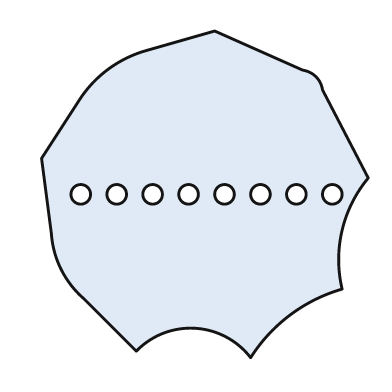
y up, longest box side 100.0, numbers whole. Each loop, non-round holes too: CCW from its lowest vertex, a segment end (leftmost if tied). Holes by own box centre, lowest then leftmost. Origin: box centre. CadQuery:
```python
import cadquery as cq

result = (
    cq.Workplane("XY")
    .moveTo(14.0, -50.0)
    .threePointArc((26.0, -37.0), (42.0, -29.0))
    .threePointArc((42.0, -11.0), (50.0, 5.0))
    .lineTo(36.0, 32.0)
    .threePointArc((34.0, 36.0), (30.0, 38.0))
    .lineTo(3.0, 50.0)
    .lineTo(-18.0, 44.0)
    .threePointArc((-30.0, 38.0), (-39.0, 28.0))
    .lineTo(-50.0, 11.0)
    .lineTo(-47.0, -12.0)
    .threePointArc((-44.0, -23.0), (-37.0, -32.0))
    .lineTo(-21.0, -48.0)
    .threePointArc((-3.0, -41.0), (14.0, -50.0))
    .close()
    .moveTo(-38.0, 0.0)
    .circle(3.0)
    .moveTo(-27.0, 0.0)
    .circle(3.0)
    .moveTo(-16.0, 0.0)
    .circle(3.0)
    .moveTo(-5.0, 0.0)
    .circle(3.0)
    .moveTo(6.0, 0.0)
    .circle(3.0)
    .moveTo(17.0, 0.0)
    .circle(3.0)
    .moveTo(28.0, 0.0)
    .circle(3.0)
    .moveTo(39.0, 0.0)
    .circle(3.0)
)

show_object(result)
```